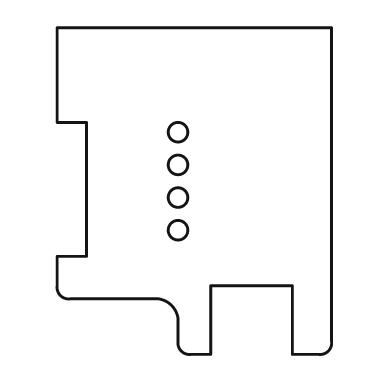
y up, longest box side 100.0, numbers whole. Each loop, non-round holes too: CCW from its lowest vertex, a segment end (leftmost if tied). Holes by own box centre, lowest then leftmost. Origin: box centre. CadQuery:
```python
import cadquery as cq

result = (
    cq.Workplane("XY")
    .moveTo(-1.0, -50.0)
    .lineTo(5.0, -50.0)
    .lineTo(5.0, -29.0)
    .lineTo(30.0, -29.0)
    .lineTo(30.0, -50.0)
    .lineTo(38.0, -50.0)
    .threePointArc((41.0, -49.0), (42.0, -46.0))
    .lineTo(42.0, 50.0)
    .lineTo(-42.0, 50.0)
    .lineTo(-42.0, 21.0)
    .lineTo(-33.0, 21.0)
    .lineTo(-33.0, -20.0)
    .lineTo(-42.0, -20.0)
    .lineTo(-42.0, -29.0)
    .threePointArc((-41.0, -32.0), (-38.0, -33.0))
    .lineTo(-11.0, -33.0)
    .threePointArc((-7.0, -35.0), (-5.0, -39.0))
    .lineTo(-5.0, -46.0)
    .threePointArc((-4.0, -49.0), (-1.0, -50.0))
    .close()
    .moveTo(-5.0, -12.0)
    .circle(3.0)
    .moveTo(-5.0, -2.0)
    .circle(3.0)
    .moveTo(-5.0, 8.0)
    .circle(3.0)
    .moveTo(-5.0, 18.0)
    .circle(3.0)
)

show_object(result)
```